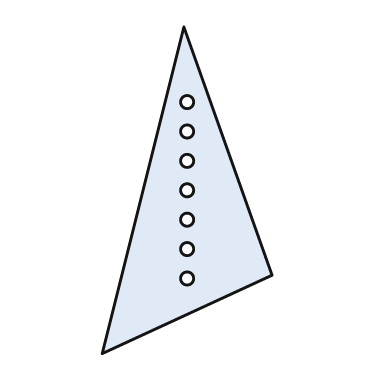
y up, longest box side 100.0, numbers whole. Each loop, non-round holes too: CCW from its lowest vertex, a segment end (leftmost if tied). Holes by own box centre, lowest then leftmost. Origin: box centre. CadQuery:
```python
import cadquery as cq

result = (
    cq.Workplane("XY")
    .moveTo(-26.0, -50.0)
    .lineTo(26.0, -26.0)
    .lineTo(-1.0, 50.0)
    .close()
    .moveTo(0.0, -27.0)
    .circle(2.0)
    .moveTo(0.0, -18.0)
    .circle(2.0)
    .moveTo(0.0, -9.0)
    .circle(2.0)
    .moveTo(0.0, 0.0)
    .circle(2.0)
    .moveTo(0.0, 9.0)
    .circle(2.0)
    .moveTo(0.0, 18.0)
    .circle(2.0)
    .moveTo(0.0, 27.0)
    .circle(2.0)
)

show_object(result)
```